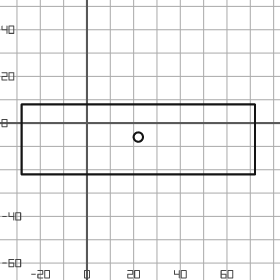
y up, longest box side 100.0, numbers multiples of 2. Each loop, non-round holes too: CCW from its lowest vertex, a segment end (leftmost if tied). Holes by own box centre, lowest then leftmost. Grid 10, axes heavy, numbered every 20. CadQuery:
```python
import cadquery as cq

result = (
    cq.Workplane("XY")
    .moveTo(-28.0, -22.0)
    .lineTo(72.0, -22.0)
    .lineTo(72.0, 8.0)
    .lineTo(-28.0, 8.0)
    .close()
    .moveTo(22.0, -6.0)
    .circle(2.0)
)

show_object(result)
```